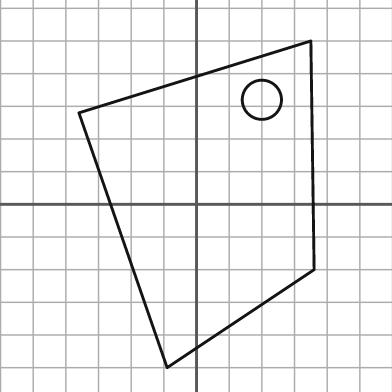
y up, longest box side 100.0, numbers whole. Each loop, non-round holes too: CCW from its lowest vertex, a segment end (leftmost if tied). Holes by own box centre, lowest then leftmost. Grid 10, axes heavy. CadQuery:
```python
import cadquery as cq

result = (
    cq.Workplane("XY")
    .moveTo(-9.0, -50.0)
    .lineTo(36.0, -20.0)
    .lineTo(35.0, 50.0)
    .lineTo(-36.0, 28.0)
    .close()
    .moveTo(20.0, 32.0)
    .circle(6.0)
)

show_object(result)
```